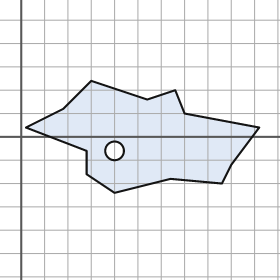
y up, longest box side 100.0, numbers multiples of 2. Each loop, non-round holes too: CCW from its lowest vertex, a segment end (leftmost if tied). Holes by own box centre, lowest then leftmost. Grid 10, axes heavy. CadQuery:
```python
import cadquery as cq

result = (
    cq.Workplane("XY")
    .moveTo(40.0, -24.0)
    .lineTo(64.0, -18.0)
    .lineTo(86.0, -20.0)
    .lineTo(90.0, -12.0)
    .lineTo(102.0, 4.0)
    .lineTo(70.0, 10.0)
    .lineTo(66.0, 20.0)
    .lineTo(54.0, 16.0)
    .lineTo(30.0, 24.0)
    .lineTo(18.0, 12.0)
    .lineTo(2.0, 4.0)
    .lineTo(28.0, -6.0)
    .lineTo(28.0, -16.0)
    .close()
    .moveTo(40.0, -6.0)
    .circle(4.0)
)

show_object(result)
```